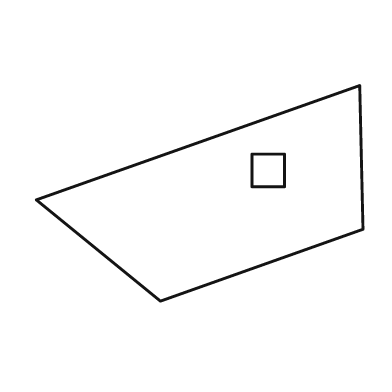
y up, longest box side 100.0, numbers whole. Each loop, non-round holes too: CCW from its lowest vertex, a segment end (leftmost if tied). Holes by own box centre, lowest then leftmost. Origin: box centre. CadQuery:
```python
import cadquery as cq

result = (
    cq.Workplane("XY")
    .moveTo(-12.0, -33.0)
    .lineTo(50.0, -11.0)
    .lineTo(49.0, 33.0)
    .lineTo(-50.0, -2.0)
    .close()
    .moveTo(16.0, 2.0)
    .lineTo(26.0, 2.0)
    .lineTo(26.0, 12.0)
    .lineTo(16.0, 12.0)
    .close()
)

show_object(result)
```